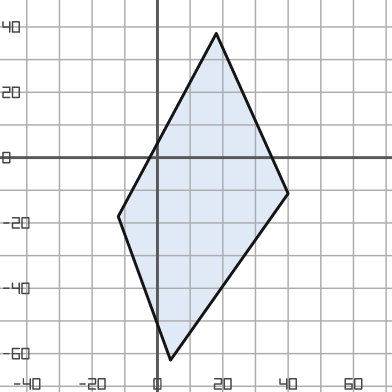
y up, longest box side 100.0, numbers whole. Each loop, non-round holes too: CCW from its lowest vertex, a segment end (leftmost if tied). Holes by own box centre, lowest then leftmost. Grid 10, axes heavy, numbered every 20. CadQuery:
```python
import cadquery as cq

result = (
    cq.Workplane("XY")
    .moveTo(4.0, -62.0)
    .lineTo(40.0, -11.0)
    .lineTo(18.0, 38.0)
    .lineTo(-12.0, -18.0)
    .close()
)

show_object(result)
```